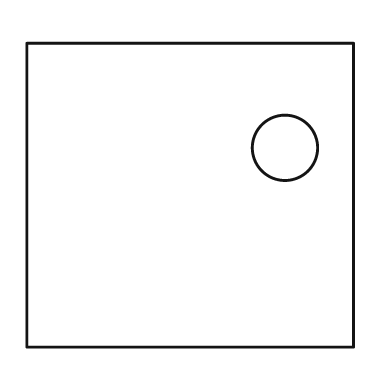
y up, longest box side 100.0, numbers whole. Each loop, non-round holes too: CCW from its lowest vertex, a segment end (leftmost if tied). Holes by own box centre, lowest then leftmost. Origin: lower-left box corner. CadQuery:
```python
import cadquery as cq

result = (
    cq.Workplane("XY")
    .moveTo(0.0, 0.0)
    .lineTo(100.0, 0.0)
    .lineTo(100.0, 93.0)
    .lineTo(0.0, 93.0)
    .close()
    .moveTo(79.0, 61.0)
    .circle(10.0)
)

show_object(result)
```